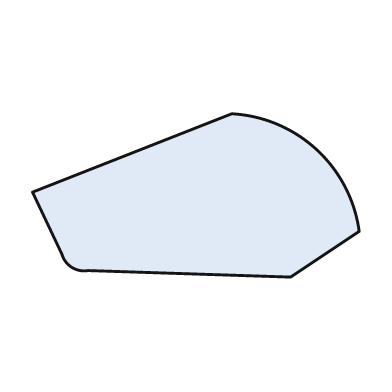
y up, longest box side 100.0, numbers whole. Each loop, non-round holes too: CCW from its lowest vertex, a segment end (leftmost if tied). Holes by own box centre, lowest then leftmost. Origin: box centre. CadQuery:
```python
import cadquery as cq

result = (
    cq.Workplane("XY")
    .moveTo(29.0, -25.0)
    .lineTo(50.0, -11.0)
    .threePointArc((37.0, 14.0), (11.0, 25.0))
    .lineTo(-50.0, 1.0)
    .lineTo(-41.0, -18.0)
    .threePointArc((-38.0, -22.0), (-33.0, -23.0))
    .close()
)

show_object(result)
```